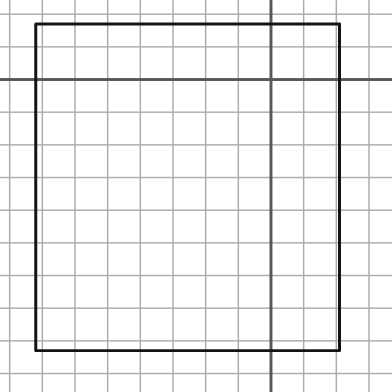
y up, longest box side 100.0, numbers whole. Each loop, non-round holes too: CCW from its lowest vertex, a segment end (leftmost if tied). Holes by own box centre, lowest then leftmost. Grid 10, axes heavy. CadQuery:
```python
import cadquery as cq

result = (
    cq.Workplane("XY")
    .moveTo(-72.0, -83.0)
    .lineTo(21.0, -83.0)
    .lineTo(21.0, 17.0)
    .lineTo(-72.0, 17.0)
    .close()
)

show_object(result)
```